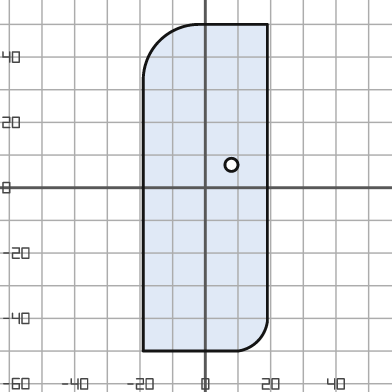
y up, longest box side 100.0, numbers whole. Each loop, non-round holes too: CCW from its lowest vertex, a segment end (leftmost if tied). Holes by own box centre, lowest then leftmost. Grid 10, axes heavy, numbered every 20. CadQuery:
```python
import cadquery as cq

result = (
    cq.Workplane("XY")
    .moveTo(-19.0, -50.0)
    .lineTo(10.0, -50.0)
    .threePointArc((16.0, -47.0), (19.0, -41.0))
    .lineTo(19.0, 50.0)
    .lineTo(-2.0, 50.0)
    .threePointArc((-14.0, 45.0), (-19.0, 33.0))
    .close()
    .moveTo(8.0, 7.0)
    .circle(2.0)
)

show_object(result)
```